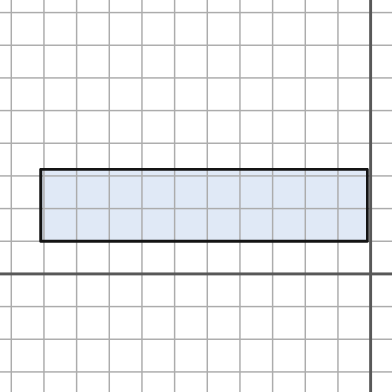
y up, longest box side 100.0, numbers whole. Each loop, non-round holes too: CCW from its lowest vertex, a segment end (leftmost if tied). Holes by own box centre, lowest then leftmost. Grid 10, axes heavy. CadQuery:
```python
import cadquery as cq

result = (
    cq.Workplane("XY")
    .moveTo(-101.0, 10.0)
    .lineTo(-1.0, 10.0)
    .lineTo(-1.0, 32.0)
    .lineTo(-101.0, 32.0)
    .close()
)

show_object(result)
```